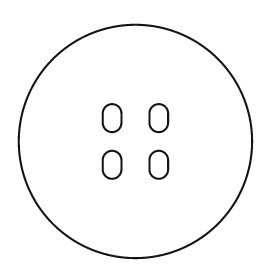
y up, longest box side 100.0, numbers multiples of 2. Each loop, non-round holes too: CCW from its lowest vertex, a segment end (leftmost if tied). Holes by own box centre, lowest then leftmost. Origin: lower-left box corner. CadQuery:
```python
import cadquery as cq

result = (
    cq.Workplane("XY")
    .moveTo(50.0, 50.0)
    .circle(50.0)
    .moveTo(36.0, 38.0)
    .threePointArc((40.0, 34.0), (44.0, 38.0))
    .lineTo(44.0, 42.0)
    .threePointArc((40.0, 46.0), (36.0, 42.0))
    .close()
    .moveTo(56.0, 38.0)
    .threePointArc((60.0, 34.0), (64.0, 38.0))
    .lineTo(64.0, 42.0)
    .threePointArc((60.0, 46.0), (56.0, 42.0))
    .close()
    .moveTo(36.0, 58.0)
    .threePointArc((40.0, 54.0), (44.0, 58.0))
    .lineTo(44.0, 62.0)
    .threePointArc((40.0, 66.0), (36.0, 62.0))
    .close()
    .moveTo(56.0, 58.0)
    .threePointArc((60.0, 54.0), (64.0, 58.0))
    .lineTo(64.0, 62.0)
    .threePointArc((60.0, 66.0), (56.0, 62.0))
    .close()
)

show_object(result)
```